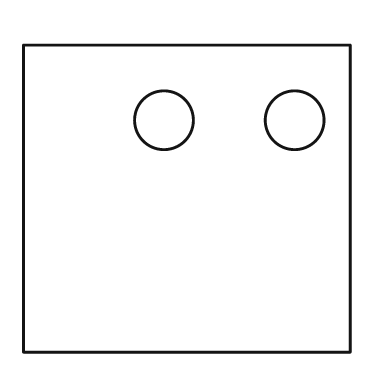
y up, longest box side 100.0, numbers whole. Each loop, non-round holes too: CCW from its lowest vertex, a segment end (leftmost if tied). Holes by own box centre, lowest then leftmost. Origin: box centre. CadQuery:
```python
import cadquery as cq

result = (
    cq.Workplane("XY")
    .moveTo(-50.0, -47.0)
    .lineTo(50.0, -47.0)
    .lineTo(50.0, 47.0)
    .lineTo(-50.0, 47.0)
    .close()
    .moveTo(-7.0, 24.0)
    .circle(9.0)
    .moveTo(33.0, 24.0)
    .circle(9.0)
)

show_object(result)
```